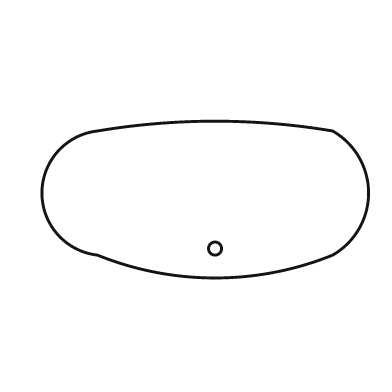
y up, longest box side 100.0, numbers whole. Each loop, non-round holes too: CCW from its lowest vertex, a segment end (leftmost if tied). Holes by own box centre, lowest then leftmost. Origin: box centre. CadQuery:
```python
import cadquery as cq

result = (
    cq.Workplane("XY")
    .moveTo(-33.0, -17.0)
    .threePointArc((3.0, -24.0), (39.0, -17.0))
    .threePointArc((50.0, 2.0), (39.0, 21.0))
    .threePointArc((3.0, 24.0), (-33.0, 21.0))
    .threePointArc((-50.0, 2.0), (-33.0, -17.0))
    .close()
    .moveTo(3.0, -15.0)
    .circle(2.0)
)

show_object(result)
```